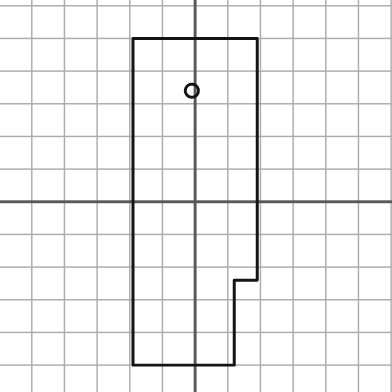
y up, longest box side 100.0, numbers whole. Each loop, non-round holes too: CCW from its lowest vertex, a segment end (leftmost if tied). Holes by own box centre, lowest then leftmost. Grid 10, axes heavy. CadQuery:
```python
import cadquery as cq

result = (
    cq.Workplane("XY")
    .moveTo(-19.0, -50.0)
    .lineTo(12.0, -50.0)
    .lineTo(12.0, -24.0)
    .lineTo(19.0, -24.0)
    .lineTo(19.0, 50.0)
    .lineTo(-19.0, 50.0)
    .close()
    .moveTo(-1.0, 34.0)
    .circle(2.0)
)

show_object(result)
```